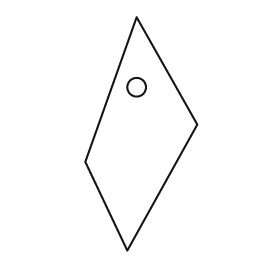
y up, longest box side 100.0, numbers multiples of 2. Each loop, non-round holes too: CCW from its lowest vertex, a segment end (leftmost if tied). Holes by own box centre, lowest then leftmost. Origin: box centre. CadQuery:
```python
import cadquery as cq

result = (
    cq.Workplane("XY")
    .moveTo(-6.0, -50.0)
    .lineTo(24.0, 4.0)
    .lineTo(-2.0, 50.0)
    .lineTo(-24.0, -12.0)
    .close()
    .moveTo(-2.0, 20.0)
    .circle(4.0)
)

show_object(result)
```